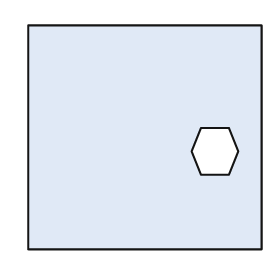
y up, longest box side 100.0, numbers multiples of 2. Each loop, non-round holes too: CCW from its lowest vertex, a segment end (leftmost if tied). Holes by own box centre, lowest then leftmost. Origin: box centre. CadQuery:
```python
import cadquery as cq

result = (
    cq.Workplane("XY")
    .moveTo(-50.0, -48.0)
    .lineTo(50.0, -48.0)
    .lineTo(50.0, 48.0)
    .lineTo(-50.0, 48.0)
    .close()
    .moveTo(24.0, -16.0)
    .lineTo(36.0, -16.0)
    .lineTo(40.0, -6.0)
    .lineTo(36.0, 4.0)
    .lineTo(24.0, 4.0)
    .lineTo(20.0, -6.0)
    .close()
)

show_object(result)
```